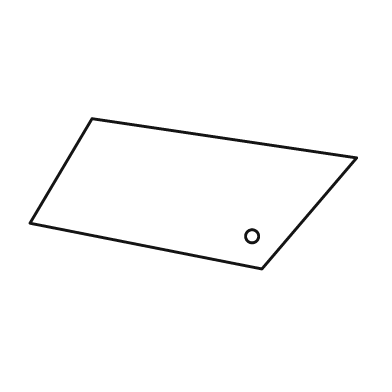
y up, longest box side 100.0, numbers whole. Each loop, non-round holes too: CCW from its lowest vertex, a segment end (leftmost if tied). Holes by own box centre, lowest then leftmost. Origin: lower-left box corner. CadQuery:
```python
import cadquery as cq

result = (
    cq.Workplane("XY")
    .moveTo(71.0, 0.0)
    .lineTo(100.0, 34.0)
    .lineTo(19.0, 46.0)
    .lineTo(0.0, 14.0)
    .close()
    .moveTo(68.0, 10.0)
    .circle(2.0)
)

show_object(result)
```